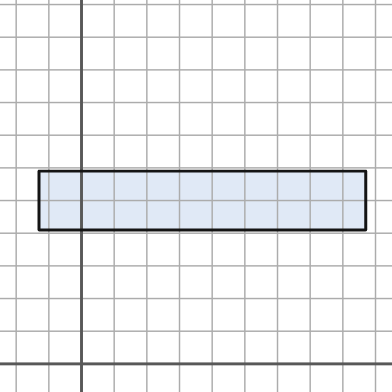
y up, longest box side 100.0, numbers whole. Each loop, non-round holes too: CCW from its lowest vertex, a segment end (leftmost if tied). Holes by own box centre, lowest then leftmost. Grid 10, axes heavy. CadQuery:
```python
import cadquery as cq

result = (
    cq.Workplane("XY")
    .moveTo(-13.0, 41.0)
    .lineTo(87.0, 41.0)
    .lineTo(87.0, 59.0)
    .lineTo(-13.0, 59.0)
    .close()
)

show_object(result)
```